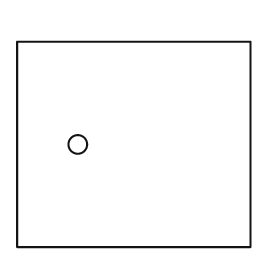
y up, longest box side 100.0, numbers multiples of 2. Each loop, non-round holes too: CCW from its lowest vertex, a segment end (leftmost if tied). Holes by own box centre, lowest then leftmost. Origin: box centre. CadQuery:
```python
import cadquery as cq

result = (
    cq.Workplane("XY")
    .moveTo(-50.0, -44.0)
    .lineTo(50.0, -44.0)
    .lineTo(50.0, 44.0)
    .lineTo(-50.0, 44.0)
    .close()
    .moveTo(-24.0, 0.0)
    .circle(4.0)
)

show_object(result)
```